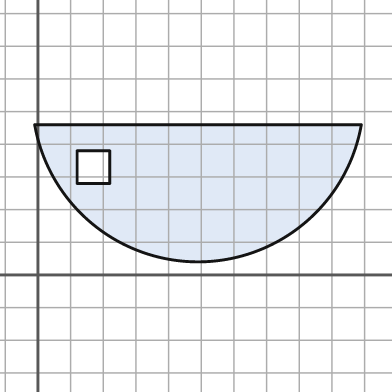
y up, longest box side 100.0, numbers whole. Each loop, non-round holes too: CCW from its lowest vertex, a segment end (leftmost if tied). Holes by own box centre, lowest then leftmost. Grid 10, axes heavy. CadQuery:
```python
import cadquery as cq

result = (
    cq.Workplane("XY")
    .moveTo(-1.0, 46.0)
    .threePointArc((49.0, 4.0), (99.0, 46.0))
    .close()
    .moveTo(12.0, 28.0)
    .lineTo(22.0, 28.0)
    .lineTo(22.0, 38.0)
    .lineTo(12.0, 38.0)
    .close()
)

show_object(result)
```